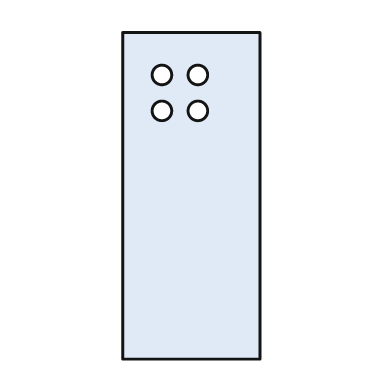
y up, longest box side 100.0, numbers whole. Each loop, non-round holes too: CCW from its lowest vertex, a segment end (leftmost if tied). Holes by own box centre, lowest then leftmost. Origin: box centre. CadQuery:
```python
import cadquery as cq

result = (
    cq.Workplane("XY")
    .moveTo(-21.0, -50.0)
    .lineTo(21.0, -50.0)
    .lineTo(21.0, 50.0)
    .lineTo(-21.0, 50.0)
    .close()
    .moveTo(-9.0, 26.0)
    .circle(3.0)
    .moveTo(2.0, 26.0)
    .circle(3.0)
    .moveTo(-9.0, 37.0)
    .circle(3.0)
    .moveTo(2.0, 37.0)
    .circle(3.0)
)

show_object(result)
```